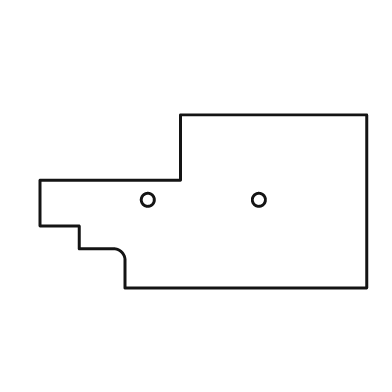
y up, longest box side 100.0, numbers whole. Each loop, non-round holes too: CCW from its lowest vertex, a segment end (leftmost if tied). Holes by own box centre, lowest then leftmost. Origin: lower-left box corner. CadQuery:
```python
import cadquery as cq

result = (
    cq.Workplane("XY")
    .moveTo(26.0, 0.0)
    .lineTo(100.0, 0.0)
    .lineTo(100.0, 53.0)
    .lineTo(43.0, 53.0)
    .lineTo(43.0, 33.0)
    .lineTo(0.0, 33.0)
    .lineTo(0.0, 19.0)
    .lineTo(12.0, 19.0)
    .lineTo(12.0, 12.0)
    .lineTo(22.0, 12.0)
    .threePointArc((25.0, 11.0), (26.0, 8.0))
    .close()
    .moveTo(33.0, 27.0)
    .circle(2.0)
    .moveTo(67.0, 27.0)
    .circle(2.0)
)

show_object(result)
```